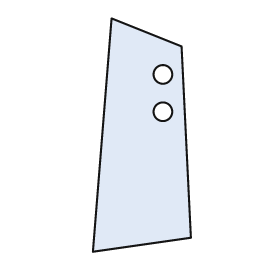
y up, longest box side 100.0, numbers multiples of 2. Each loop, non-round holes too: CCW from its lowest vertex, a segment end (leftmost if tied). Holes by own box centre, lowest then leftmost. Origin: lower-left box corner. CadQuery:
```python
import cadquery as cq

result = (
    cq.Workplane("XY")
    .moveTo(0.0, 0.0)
    .lineTo(42.0, 6.0)
    .lineTo(38.0, 88.0)
    .lineTo(8.0, 100.0)
    .close()
    .moveTo(30.0, 60.0)
    .circle(4.0)
    .moveTo(30.0, 76.0)
    .circle(4.0)
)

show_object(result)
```